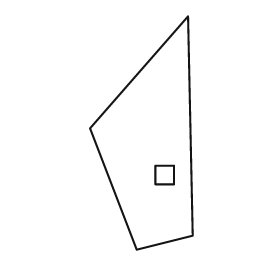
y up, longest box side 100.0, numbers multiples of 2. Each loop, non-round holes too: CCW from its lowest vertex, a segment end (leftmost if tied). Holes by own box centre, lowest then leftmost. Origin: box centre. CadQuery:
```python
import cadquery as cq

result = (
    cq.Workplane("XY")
    .moveTo(-2.0, -50.0)
    .lineTo(22.0, -44.0)
    .lineTo(20.0, 50.0)
    .lineTo(-22.0, 2.0)
    .close()
    .moveTo(6.0, -22.0)
    .lineTo(14.0, -22.0)
    .lineTo(14.0, -14.0)
    .lineTo(6.0, -14.0)
    .close()
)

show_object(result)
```